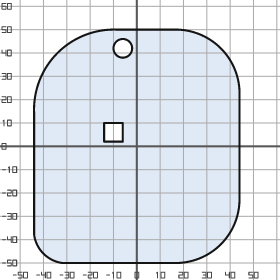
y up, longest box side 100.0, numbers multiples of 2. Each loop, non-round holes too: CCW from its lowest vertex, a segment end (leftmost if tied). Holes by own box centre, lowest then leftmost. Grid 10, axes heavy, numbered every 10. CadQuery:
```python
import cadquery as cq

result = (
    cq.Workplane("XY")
    .moveTo(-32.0, -50.0)
    .lineTo(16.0, -50.0)
    .threePointArc((36.0, -42.0), (44.0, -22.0))
    .lineTo(44.0, 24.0)
    .threePointArc((36.0, 42.0), (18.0, 50.0))
    .lineTo(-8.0, 50.0)
    .threePointArc((-34.0, 40.0), (-44.0, 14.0))
    .lineTo(-44.0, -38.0)
    .threePointArc((-40.0, -46.0), (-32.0, -50.0))
    .close()
    .moveTo(-14.0, 2.0)
    .lineTo(-6.0, 2.0)
    .lineTo(-6.0, 10.0)
    .lineTo(-14.0, 10.0)
    .close()
    .moveTo(-6.0, 42.0)
    .circle(4.0)
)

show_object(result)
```